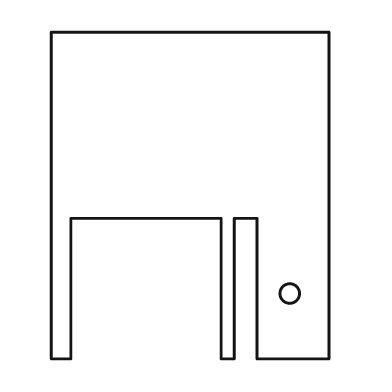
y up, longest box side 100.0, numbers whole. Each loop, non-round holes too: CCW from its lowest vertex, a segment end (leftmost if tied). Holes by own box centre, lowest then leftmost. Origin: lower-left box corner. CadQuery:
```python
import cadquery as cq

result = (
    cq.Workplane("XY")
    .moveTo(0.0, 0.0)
    .lineTo(6.0, 0.0)
    .lineTo(6.0, 43.0)
    .lineTo(52.0, 43.0)
    .lineTo(52.0, 0.0)
    .lineTo(56.0, 0.0)
    .lineTo(56.0, 43.0)
    .lineTo(63.0, 43.0)
    .lineTo(63.0, 0.0)
    .lineTo(85.0, 0.0)
    .lineTo(85.0, 100.0)
    .lineTo(0.0, 100.0)
    .close()
    .moveTo(73.0, 20.0)
    .circle(3.0)
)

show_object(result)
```